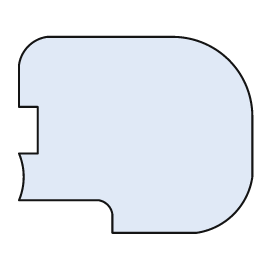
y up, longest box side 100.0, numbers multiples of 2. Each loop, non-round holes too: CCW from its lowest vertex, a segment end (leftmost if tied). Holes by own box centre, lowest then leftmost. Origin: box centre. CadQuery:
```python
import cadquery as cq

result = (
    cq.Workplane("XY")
    .moveTo(-10.0, -42.0)
    .lineTo(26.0, -42.0)
    .threePointArc((42.0, -34.0), (50.0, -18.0))
    .lineTo(50.0, 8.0)
    .threePointArc((40.0, 32.0), (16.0, 42.0))
    .lineTo(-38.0, 42.0)
    .threePointArc((-46.0, 38.0), (-50.0, 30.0))
    .lineTo(-50.0, 12.0)
    .lineTo(-42.0, 12.0)
    .lineTo(-42.0, -8.0)
    .lineTo(-50.0, -8.0)
    .threePointArc((-48.0, -18.0), (-50.0, -28.0))
    .lineTo(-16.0, -28.0)
    .threePointArc((-12.0, -30.0), (-10.0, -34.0))
    .close()
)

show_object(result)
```